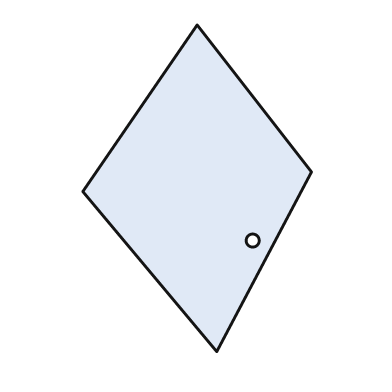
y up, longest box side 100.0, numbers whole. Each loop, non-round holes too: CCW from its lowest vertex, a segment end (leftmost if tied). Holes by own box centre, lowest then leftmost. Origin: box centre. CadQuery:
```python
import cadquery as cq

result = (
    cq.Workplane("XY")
    .moveTo(6.0, -50.0)
    .lineTo(35.0, 5.0)
    .lineTo(0.0, 50.0)
    .lineTo(-35.0, -1.0)
    .close()
    .moveTo(17.0, -16.0)
    .circle(2.0)
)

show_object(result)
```